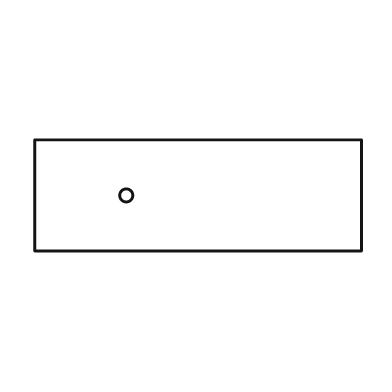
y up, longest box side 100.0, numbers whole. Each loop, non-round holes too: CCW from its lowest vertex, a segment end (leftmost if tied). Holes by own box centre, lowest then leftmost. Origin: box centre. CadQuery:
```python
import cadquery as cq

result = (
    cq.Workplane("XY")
    .moveTo(-50.0, -17.0)
    .lineTo(50.0, -17.0)
    .lineTo(50.0, 17.0)
    .lineTo(-50.0, 17.0)
    .close()
    .moveTo(-22.0, 0.0)
    .circle(2.0)
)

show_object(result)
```